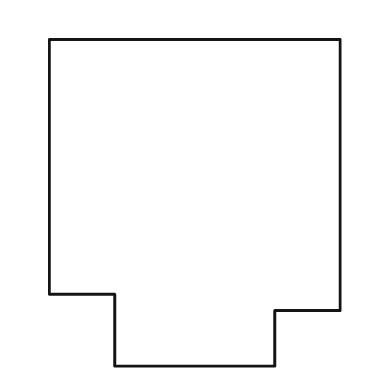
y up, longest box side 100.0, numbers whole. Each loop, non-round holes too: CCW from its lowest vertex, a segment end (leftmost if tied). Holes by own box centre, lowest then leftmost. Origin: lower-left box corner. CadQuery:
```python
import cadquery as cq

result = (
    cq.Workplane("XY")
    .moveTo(20.0, 0.0)
    .lineTo(69.0, 0.0)
    .lineTo(69.0, 17.0)
    .lineTo(89.0, 17.0)
    .lineTo(89.0, 100.0)
    .lineTo(0.0, 100.0)
    .lineTo(0.0, 22.0)
    .lineTo(20.0, 22.0)
    .close()
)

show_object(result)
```